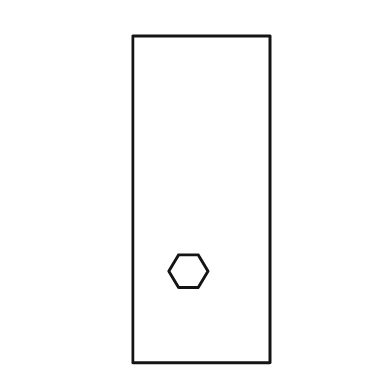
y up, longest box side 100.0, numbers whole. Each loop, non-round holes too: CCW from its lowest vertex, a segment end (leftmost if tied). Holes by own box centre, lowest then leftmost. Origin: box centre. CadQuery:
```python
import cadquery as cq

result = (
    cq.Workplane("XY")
    .moveTo(-21.0, -50.0)
    .lineTo(21.0, -50.0)
    .lineTo(21.0, 50.0)
    .lineTo(-21.0, 50.0)
    .close()
    .moveTo(-7.0, -27.0)
    .lineTo(-1.0, -27.0)
    .lineTo(2.0, -22.0)
    .lineTo(-1.0, -17.0)
    .lineTo(-7.0, -17.0)
    .lineTo(-10.0, -22.0)
    .close()
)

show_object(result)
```